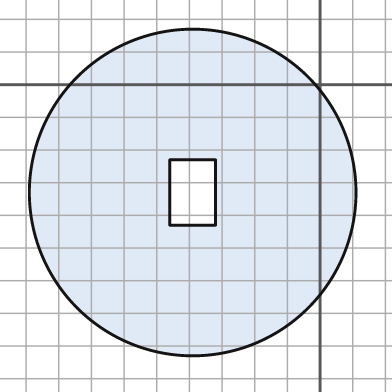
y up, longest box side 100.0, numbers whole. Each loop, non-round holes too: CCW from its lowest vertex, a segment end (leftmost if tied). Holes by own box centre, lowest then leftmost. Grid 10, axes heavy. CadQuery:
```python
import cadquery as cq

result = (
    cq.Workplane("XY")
    .moveTo(-39.0, -33.0)
    .circle(50.0)
    .moveTo(-46.0, -43.0)
    .lineTo(-32.0, -43.0)
    .lineTo(-32.0, -23.0)
    .lineTo(-46.0, -23.0)
    .close()
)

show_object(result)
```